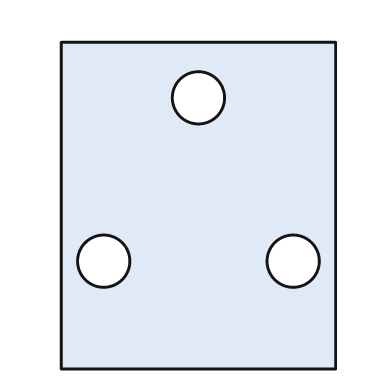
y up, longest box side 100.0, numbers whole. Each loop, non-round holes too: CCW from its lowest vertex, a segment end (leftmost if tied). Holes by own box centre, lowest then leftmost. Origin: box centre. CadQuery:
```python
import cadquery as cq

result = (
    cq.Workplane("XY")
    .moveTo(-42.0, -50.0)
    .lineTo(42.0, -50.0)
    .lineTo(42.0, 50.0)
    .lineTo(-42.0, 50.0)
    .close()
    .moveTo(-29.0, -17.0)
    .circle(8.0)
    .moveTo(29.0, -17.0)
    .circle(8.0)
    .moveTo(0.0, 33.0)
    .circle(8.0)
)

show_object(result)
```